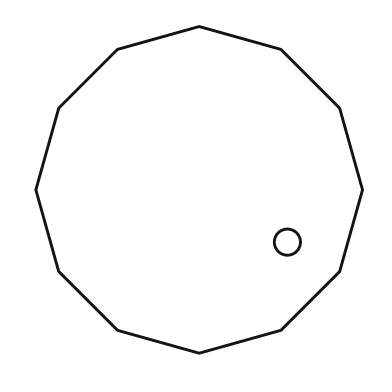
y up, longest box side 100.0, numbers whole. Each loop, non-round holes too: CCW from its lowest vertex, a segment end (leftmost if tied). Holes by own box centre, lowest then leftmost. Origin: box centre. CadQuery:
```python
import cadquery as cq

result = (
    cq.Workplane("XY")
    .moveTo(0.0, -50.0)
    .lineTo(25.0, -43.0)
    .lineTo(43.0, -25.0)
    .lineTo(50.0, 0.0)
    .lineTo(43.0, 25.0)
    .lineTo(25.0, 43.0)
    .lineTo(0.0, 50.0)
    .lineTo(-25.0, 43.0)
    .lineTo(-43.0, 25.0)
    .lineTo(-50.0, 0.0)
    .lineTo(-43.0, -25.0)
    .lineTo(-25.0, -43.0)
    .close()
    .moveTo(27.0, -16.0)
    .circle(4.0)
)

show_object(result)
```